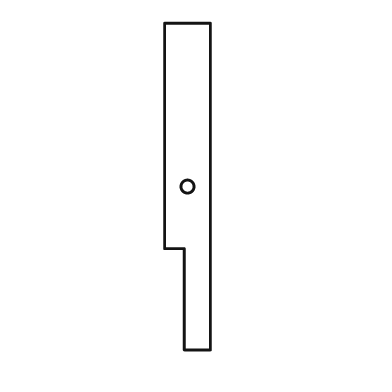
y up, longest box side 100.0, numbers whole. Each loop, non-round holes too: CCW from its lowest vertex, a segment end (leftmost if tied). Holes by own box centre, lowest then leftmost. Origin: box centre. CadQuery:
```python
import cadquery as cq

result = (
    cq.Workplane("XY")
    .moveTo(-1.0, -50.0)
    .lineTo(7.0, -50.0)
    .lineTo(7.0, 50.0)
    .lineTo(-7.0, 50.0)
    .lineTo(-7.0, -19.0)
    .lineTo(-1.0, -19.0)
    .close()
    .moveTo(0.0, 0.0)
    .circle(2.0)
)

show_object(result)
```